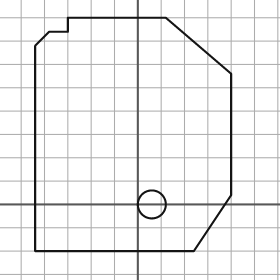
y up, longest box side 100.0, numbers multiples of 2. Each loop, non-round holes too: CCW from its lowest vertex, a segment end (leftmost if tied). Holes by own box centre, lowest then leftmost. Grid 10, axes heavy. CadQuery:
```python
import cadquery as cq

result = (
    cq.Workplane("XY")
    .moveTo(-44.0, -20.0)
    .lineTo(24.0, -20.0)
    .lineTo(40.0, 4.0)
    .lineTo(40.0, 56.0)
    .lineTo(12.0, 80.0)
    .lineTo(-30.0, 80.0)
    .lineTo(-30.0, 74.0)
    .lineTo(-38.0, 74.0)
    .lineTo(-44.0, 68.0)
    .close()
    .moveTo(6.0, 0.0)
    .circle(6.0)
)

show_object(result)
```